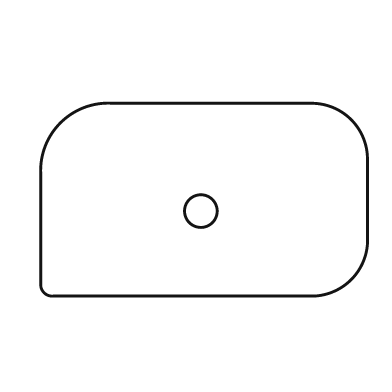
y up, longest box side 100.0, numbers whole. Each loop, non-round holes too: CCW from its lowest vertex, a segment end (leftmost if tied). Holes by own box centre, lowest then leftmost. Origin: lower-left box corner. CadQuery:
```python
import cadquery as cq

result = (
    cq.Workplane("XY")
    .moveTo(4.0, 0.0)
    .lineTo(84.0, 0.0)
    .threePointArc((95.0, 5.0), (100.0, 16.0))
    .lineTo(100.0, 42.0)
    .threePointArc((95.0, 54.0), (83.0, 59.0))
    .lineTo(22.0, 59.0)
    .threePointArc((6.0, 53.0), (0.0, 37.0))
    .lineTo(0.0, 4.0)
    .threePointArc((1.0, 1.0), (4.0, 0.0))
    .close()
    .moveTo(49.0, 26.0)
    .circle(5.0)
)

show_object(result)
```